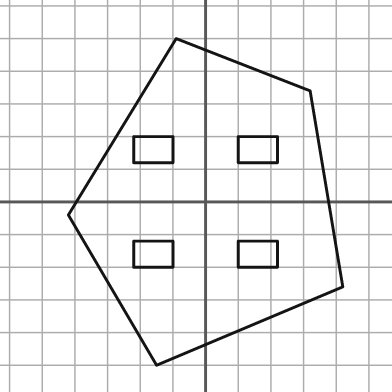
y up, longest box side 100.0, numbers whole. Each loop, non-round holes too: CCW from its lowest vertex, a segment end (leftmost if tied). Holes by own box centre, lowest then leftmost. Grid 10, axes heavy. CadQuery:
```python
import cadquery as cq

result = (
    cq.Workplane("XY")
    .moveTo(-15.0, -50.0)
    .lineTo(42.0, -26.0)
    .lineTo(32.0, 34.0)
    .lineTo(-9.0, 50.0)
    .lineTo(-42.0, -4.0)
    .close()
    .moveTo(-22.0, -20.0)
    .lineTo(-10.0, -20.0)
    .lineTo(-10.0, -12.0)
    .lineTo(-22.0, -12.0)
    .close()
    .moveTo(10.0, -20.0)
    .lineTo(22.0, -20.0)
    .lineTo(22.0, -12.0)
    .lineTo(10.0, -12.0)
    .close()
    .moveTo(-22.0, 12.0)
    .lineTo(-10.0, 12.0)
    .lineTo(-10.0, 20.0)
    .lineTo(-22.0, 20.0)
    .close()
    .moveTo(10.0, 12.0)
    .lineTo(22.0, 12.0)
    .lineTo(22.0, 20.0)
    .lineTo(10.0, 20.0)
    .close()
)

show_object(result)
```